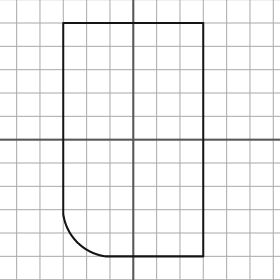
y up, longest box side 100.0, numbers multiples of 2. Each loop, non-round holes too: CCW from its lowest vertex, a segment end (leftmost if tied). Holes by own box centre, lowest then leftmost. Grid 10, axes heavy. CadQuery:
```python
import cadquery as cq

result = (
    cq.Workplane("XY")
    .moveTo(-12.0, -50.0)
    .lineTo(30.0, -50.0)
    .lineTo(30.0, 50.0)
    .lineTo(-30.0, 50.0)
    .lineTo(-30.0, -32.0)
    .threePointArc((-24.0, -44.0), (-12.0, -50.0))
    .close()
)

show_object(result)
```